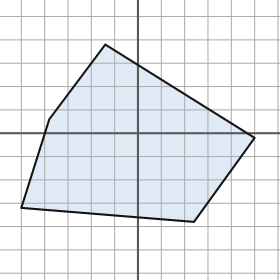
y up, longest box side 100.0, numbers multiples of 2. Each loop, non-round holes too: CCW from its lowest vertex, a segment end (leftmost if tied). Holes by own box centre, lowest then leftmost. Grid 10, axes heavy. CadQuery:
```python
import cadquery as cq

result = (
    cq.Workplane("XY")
    .moveTo(24.0, -38.0)
    .lineTo(50.0, -2.0)
    .lineTo(-14.0, 38.0)
    .lineTo(-38.0, 6.0)
    .lineTo(-50.0, -32.0)
    .close()
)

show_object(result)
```